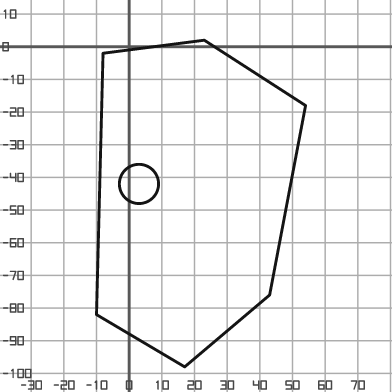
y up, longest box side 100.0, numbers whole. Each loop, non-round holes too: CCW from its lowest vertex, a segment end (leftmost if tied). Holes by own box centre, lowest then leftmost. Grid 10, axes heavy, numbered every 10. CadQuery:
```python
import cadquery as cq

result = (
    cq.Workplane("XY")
    .moveTo(17.0, -98.0)
    .lineTo(43.0, -76.0)
    .lineTo(54.0, -18.0)
    .lineTo(23.0, 2.0)
    .lineTo(-8.0, -2.0)
    .lineTo(-10.0, -82.0)
    .close()
    .moveTo(3.0, -42.0)
    .circle(6.0)
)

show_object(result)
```